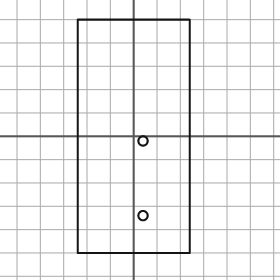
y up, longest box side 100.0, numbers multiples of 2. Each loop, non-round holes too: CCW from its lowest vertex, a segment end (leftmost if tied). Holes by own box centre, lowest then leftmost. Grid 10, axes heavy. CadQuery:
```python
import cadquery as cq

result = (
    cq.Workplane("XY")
    .moveTo(-24.0, -50.0)
    .lineTo(24.0, -50.0)
    .lineTo(24.0, 50.0)
    .lineTo(-24.0, 50.0)
    .close()
    .moveTo(4.0, -34.0)
    .circle(2.0)
    .moveTo(4.0, -2.0)
    .circle(2.0)
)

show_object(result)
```